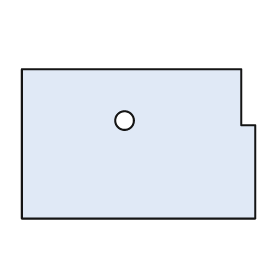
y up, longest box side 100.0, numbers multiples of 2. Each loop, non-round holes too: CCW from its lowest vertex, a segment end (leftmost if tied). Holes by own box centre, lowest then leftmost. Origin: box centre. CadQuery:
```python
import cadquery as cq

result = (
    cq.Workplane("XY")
    .moveTo(-50.0, -32.0)
    .lineTo(50.0, -32.0)
    .lineTo(50.0, 8.0)
    .lineTo(44.0, 8.0)
    .lineTo(44.0, 32.0)
    .lineTo(-50.0, 32.0)
    .close()
    .moveTo(-6.0, 10.0)
    .circle(4.0)
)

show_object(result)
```